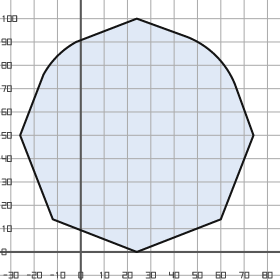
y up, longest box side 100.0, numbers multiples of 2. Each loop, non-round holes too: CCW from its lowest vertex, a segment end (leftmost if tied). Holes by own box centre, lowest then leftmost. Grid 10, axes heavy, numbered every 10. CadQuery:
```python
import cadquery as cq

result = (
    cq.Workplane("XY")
    .moveTo(24.0, 0.0)
    .lineTo(60.0, 14.0)
    .lineTo(74.0, 50.0)
    .lineTo(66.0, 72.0)
    .threePointArc((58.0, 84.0), (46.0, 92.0))
    .lineTo(24.0, 100.0)
    .lineTo(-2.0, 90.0)
    .threePointArc((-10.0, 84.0), (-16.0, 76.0))
    .lineTo(-26.0, 50.0)
    .lineTo(-12.0, 14.0)
    .close()
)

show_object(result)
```